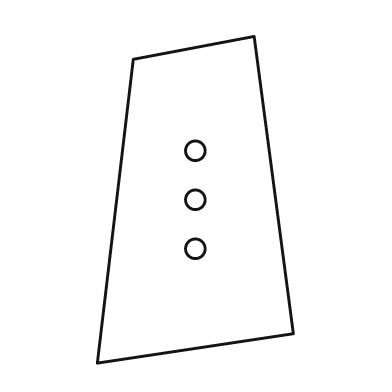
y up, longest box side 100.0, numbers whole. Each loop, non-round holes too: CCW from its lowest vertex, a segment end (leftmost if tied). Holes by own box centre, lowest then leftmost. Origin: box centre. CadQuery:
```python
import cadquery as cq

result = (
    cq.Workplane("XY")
    .moveTo(-30.0, -50.0)
    .lineTo(30.0, -41.0)
    .lineTo(18.0, 50.0)
    .lineTo(-19.0, 43.0)
    .close()
    .moveTo(0.0, -15.0)
    .circle(3.0)
    .moveTo(0.0, 0.0)
    .circle(3.0)
    .moveTo(0.0, 15.0)
    .circle(3.0)
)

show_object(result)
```